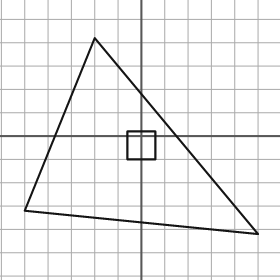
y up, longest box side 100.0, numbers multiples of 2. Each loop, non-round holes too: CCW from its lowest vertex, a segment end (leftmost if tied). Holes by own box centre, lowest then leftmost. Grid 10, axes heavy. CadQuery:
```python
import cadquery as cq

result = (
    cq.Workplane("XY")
    .moveTo(50.0, -42.0)
    .lineTo(-20.0, 42.0)
    .lineTo(-50.0, -32.0)
    .close()
    .moveTo(-6.0, -10.0)
    .lineTo(6.0, -10.0)
    .lineTo(6.0, 2.0)
    .lineTo(-6.0, 2.0)
    .close()
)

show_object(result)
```